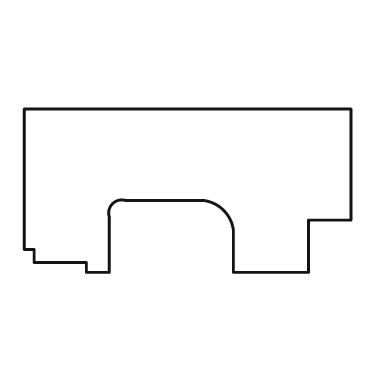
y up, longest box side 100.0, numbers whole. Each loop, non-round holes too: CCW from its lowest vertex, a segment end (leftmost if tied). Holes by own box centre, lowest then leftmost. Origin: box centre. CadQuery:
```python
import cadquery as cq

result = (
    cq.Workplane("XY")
    .moveTo(-31.0, -25.0)
    .lineTo(-24.0, -25.0)
    .lineTo(-24.0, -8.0)
    .threePointArc((-23.0, -4.0), (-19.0, -3.0))
    .lineTo(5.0, -3.0)
    .threePointArc((11.0, -6.0), (14.0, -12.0))
    .lineTo(14.0, -25.0)
    .lineTo(37.0, -25.0)
    .lineTo(37.0, -9.0)
    .lineTo(50.0, -9.0)
    .lineTo(50.0, 25.0)
    .lineTo(-50.0, 25.0)
    .lineTo(-50.0, -18.0)
    .lineTo(-47.0, -18.0)
    .lineTo(-47.0, -22.0)
    .lineTo(-31.0, -22.0)
    .close()
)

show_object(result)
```